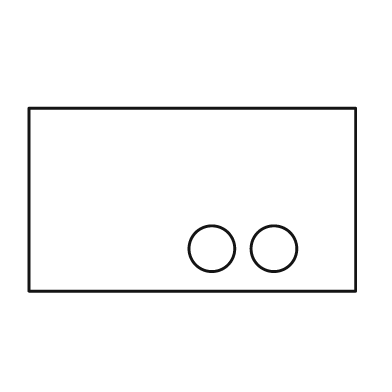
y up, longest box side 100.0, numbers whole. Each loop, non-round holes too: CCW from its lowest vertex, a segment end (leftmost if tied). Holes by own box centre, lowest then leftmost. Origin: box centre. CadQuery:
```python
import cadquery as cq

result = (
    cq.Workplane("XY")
    .moveTo(-50.0, -28.0)
    .lineTo(50.0, -28.0)
    .lineTo(50.0, 28.0)
    .lineTo(-50.0, 28.0)
    .close()
    .moveTo(6.0, -15.0)
    .circle(7.0)
    .moveTo(25.0, -15.0)
    .circle(7.0)
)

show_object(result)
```